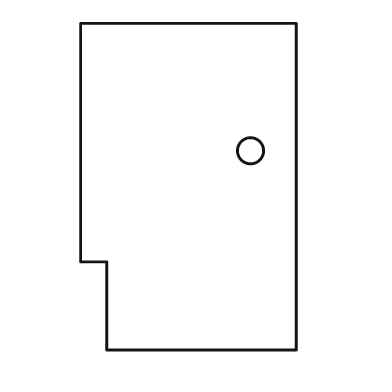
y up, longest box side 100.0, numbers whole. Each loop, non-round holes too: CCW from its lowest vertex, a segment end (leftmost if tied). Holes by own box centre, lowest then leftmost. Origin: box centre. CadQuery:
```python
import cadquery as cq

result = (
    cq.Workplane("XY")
    .moveTo(-25.0, -50.0)
    .lineTo(33.0, -50.0)
    .lineTo(33.0, 50.0)
    .lineTo(-33.0, 50.0)
    .lineTo(-33.0, -23.0)
    .lineTo(-25.0, -23.0)
    .close()
    .moveTo(19.0, 11.0)
    .circle(4.0)
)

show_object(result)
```